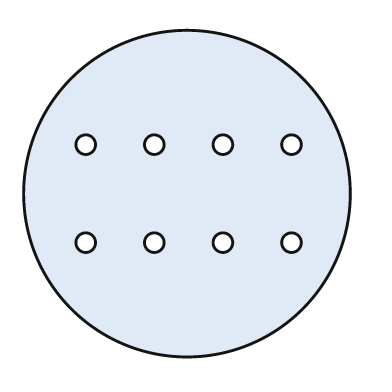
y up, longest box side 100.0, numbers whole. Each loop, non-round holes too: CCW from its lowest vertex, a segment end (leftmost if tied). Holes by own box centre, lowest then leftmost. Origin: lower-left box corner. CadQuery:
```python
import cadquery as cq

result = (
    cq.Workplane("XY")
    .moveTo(50.0, 50.0)
    .circle(50.0)
    .moveTo(19.0, 35.0)
    .circle(3.0)
    .moveTo(40.0, 35.0)
    .circle(3.0)
    .moveTo(61.0, 35.0)
    .circle(3.0)
    .moveTo(82.0, 35.0)
    .circle(3.0)
    .moveTo(19.0, 65.0)
    .circle(3.0)
    .moveTo(40.0, 65.0)
    .circle(3.0)
    .moveTo(61.0, 65.0)
    .circle(3.0)
    .moveTo(82.0, 65.0)
    .circle(3.0)
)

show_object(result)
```